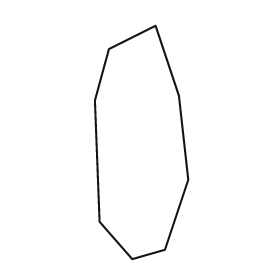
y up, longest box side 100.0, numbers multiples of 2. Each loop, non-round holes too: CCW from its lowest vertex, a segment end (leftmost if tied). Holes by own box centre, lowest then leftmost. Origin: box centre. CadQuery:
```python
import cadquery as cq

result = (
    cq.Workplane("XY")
    .moveTo(-4.0, -50.0)
    .lineTo(10.0, -46.0)
    .lineTo(20.0, -16.0)
    .lineTo(16.0, 20.0)
    .lineTo(6.0, 50.0)
    .lineTo(-14.0, 40.0)
    .lineTo(-20.0, 18.0)
    .lineTo(-18.0, -34.0)
    .close()
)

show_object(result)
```